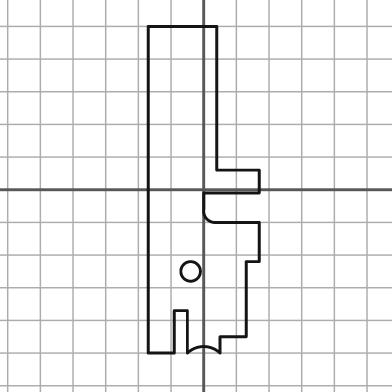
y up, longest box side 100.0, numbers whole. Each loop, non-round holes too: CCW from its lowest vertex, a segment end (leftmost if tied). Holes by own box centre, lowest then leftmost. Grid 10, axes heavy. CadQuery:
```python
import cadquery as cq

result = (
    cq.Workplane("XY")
    .moveTo(-17.0, -50.0)
    .lineTo(-9.0, -50.0)
    .lineTo(-9.0, -37.0)
    .lineTo(-5.0, -37.0)
    .lineTo(-5.0, -50.0)
    .threePointArc((0.0, -48.0), (5.0, -50.0))
    .lineTo(5.0, -45.0)
    .lineTo(13.0, -45.0)
    .lineTo(13.0, -22.0)
    .lineTo(17.0, -22.0)
    .lineTo(17.0, -10.0)
    .lineTo(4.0, -10.0)
    .threePointArc((1.0, -9.0), (0.0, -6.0))
    .lineTo(0.0, -1.0)
    .lineTo(17.0, -1.0)
    .lineTo(17.0, 6.0)
    .lineTo(4.0, 6.0)
    .lineTo(4.0, 50.0)
    .lineTo(-17.0, 50.0)
    .close()
    .moveTo(-4.0, -25.0)
    .circle(3.0)
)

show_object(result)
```